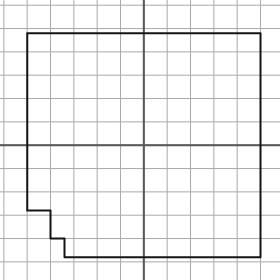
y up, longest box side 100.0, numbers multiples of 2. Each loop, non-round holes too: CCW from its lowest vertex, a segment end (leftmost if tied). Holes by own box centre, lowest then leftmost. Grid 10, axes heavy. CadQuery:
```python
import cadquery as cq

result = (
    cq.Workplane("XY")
    .moveTo(-34.0, -48.0)
    .lineTo(50.0, -48.0)
    .lineTo(50.0, 48.0)
    .lineTo(-50.0, 48.0)
    .lineTo(-50.0, -28.0)
    .lineTo(-40.0, -28.0)
    .lineTo(-40.0, -40.0)
    .lineTo(-34.0, -40.0)
    .close()
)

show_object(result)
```